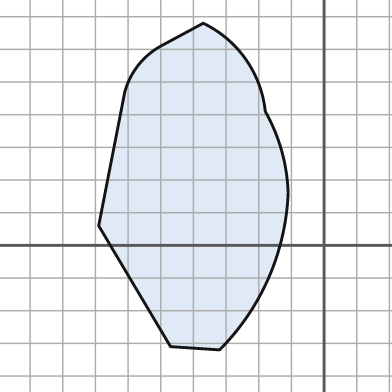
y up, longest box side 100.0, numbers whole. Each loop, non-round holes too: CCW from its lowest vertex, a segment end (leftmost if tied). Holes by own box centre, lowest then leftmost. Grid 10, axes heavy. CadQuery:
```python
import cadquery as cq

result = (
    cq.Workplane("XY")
    .moveTo(-32.0, -32.0)
    .threePointArc((-17.0, -10.0), (-11.0, 16.0))
    .threePointArc((-13.0, 29.0), (-18.0, 41.0))
    .threePointArc((-24.0, 57.0), (-37.0, 68.0))
    .lineTo(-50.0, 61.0)
    .threePointArc((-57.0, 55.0), (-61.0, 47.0))
    .lineTo(-69.0, 6.0)
    .lineTo(-47.0, -31.0)
    .close()
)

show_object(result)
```